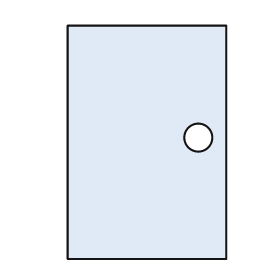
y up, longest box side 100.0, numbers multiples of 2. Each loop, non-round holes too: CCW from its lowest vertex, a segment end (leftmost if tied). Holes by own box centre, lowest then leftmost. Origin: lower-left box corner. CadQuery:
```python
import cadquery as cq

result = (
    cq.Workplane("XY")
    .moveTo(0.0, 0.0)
    .lineTo(68.0, 0.0)
    .lineTo(68.0, 100.0)
    .lineTo(0.0, 100.0)
    .close()
    .moveTo(56.0, 52.0)
    .circle(6.0)
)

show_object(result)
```